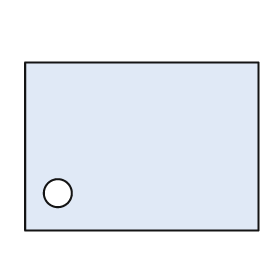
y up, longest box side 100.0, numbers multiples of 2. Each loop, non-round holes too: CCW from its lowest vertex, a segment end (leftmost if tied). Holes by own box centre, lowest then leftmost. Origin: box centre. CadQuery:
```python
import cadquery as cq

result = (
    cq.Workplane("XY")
    .moveTo(-50.0, -36.0)
    .lineTo(50.0, -36.0)
    .lineTo(50.0, 36.0)
    .lineTo(-50.0, 36.0)
    .close()
    .moveTo(-36.0, -20.0)
    .circle(6.0)
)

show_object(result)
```